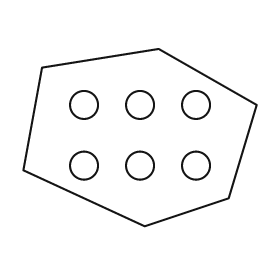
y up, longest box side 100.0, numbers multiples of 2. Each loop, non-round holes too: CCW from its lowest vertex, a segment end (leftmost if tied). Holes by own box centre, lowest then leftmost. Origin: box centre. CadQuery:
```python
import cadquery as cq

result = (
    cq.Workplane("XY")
    .moveTo(2.0, -38.0)
    .lineTo(38.0, -26.0)
    .lineTo(50.0, 14.0)
    .lineTo(8.0, 38.0)
    .lineTo(-42.0, 30.0)
    .lineTo(-50.0, -14.0)
    .close()
    .moveTo(-24.0, -12.0)
    .circle(6.0)
    .moveTo(0.0, -12.0)
    .circle(6.0)
    .moveTo(24.0, -12.0)
    .circle(6.0)
    .moveTo(-24.0, 14.0)
    .circle(6.0)
    .moveTo(0.0, 14.0)
    .circle(6.0)
    .moveTo(24.0, 14.0)
    .circle(6.0)
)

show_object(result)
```